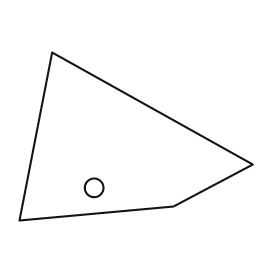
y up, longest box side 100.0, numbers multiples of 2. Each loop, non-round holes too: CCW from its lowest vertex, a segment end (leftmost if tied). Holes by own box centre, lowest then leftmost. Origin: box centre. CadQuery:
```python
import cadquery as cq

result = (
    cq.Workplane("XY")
    .moveTo(-50.0, -36.0)
    .lineTo(16.0, -30.0)
    .lineTo(50.0, -12.0)
    .lineTo(-36.0, 36.0)
    .close()
    .moveTo(-18.0, -22.0)
    .circle(4.0)
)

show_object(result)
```